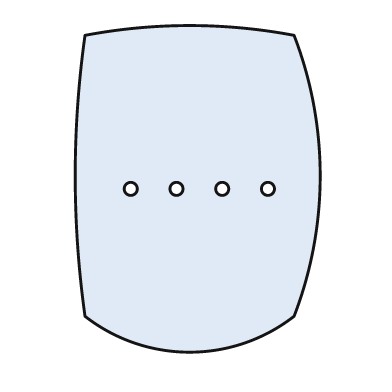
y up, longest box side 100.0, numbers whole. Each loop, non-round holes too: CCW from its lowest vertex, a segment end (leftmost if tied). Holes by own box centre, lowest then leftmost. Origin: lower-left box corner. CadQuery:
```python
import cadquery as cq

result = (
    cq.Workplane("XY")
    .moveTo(3.0, 11.0)
    .threePointArc((35.0, 0.0), (67.0, 11.0))
    .threePointArc((75.0, 54.0), (67.0, 97.0))
    .threePointArc((35.0, 100.0), (3.0, 97.0))
    .threePointArc((0.0, 54.0), (3.0, 11.0))
    .close()
    .moveTo(17.0, 50.0)
    .circle(2.0)
    .moveTo(31.0, 50.0)
    .circle(2.0)
    .moveTo(45.0, 50.0)
    .circle(2.0)
    .moveTo(59.0, 50.0)
    .circle(2.0)
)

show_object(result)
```